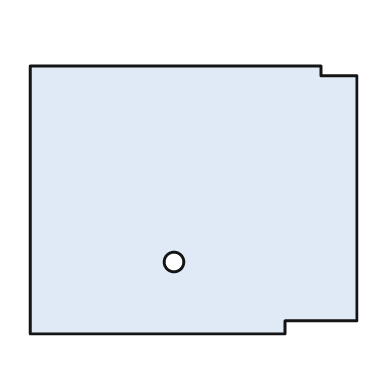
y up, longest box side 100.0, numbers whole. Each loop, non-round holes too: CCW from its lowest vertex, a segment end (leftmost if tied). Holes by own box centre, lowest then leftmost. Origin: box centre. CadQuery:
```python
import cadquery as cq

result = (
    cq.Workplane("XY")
    .moveTo(-50.0, -41.0)
    .lineTo(28.0, -41.0)
    .lineTo(28.0, -37.0)
    .lineTo(50.0, -37.0)
    .lineTo(50.0, 38.0)
    .lineTo(39.0, 38.0)
    .lineTo(39.0, 41.0)
    .lineTo(-50.0, 41.0)
    .close()
    .moveTo(-6.0, -19.0)
    .circle(3.0)
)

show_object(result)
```